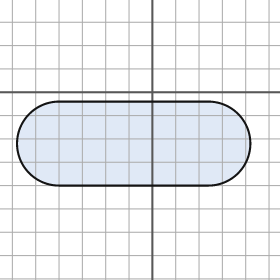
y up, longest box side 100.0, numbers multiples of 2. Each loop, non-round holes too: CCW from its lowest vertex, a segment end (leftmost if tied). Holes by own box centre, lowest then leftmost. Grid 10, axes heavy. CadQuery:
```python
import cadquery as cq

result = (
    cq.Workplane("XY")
    .moveTo(-40.0, -40.0)
    .lineTo(24.0, -40.0)
    .threePointArc((42.0, -22.0), (24.0, -4.0))
    .lineTo(-40.0, -4.0)
    .threePointArc((-58.0, -22.0), (-40.0, -40.0))
    .close()
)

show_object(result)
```